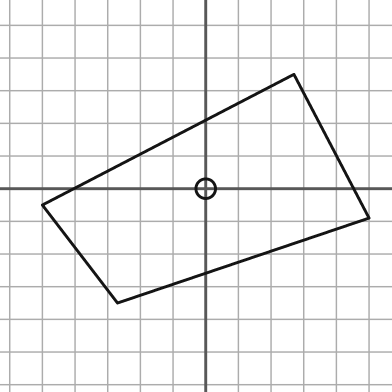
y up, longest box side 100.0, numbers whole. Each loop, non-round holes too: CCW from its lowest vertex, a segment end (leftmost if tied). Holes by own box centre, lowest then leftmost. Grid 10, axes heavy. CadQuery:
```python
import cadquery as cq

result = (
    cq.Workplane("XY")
    .moveTo(-27.0, -35.0)
    .lineTo(50.0, -9.0)
    .lineTo(27.0, 35.0)
    .lineTo(-50.0, -5.0)
    .close()
    .moveTo(0.0, 0.0)
    .circle(3.0)
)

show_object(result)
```